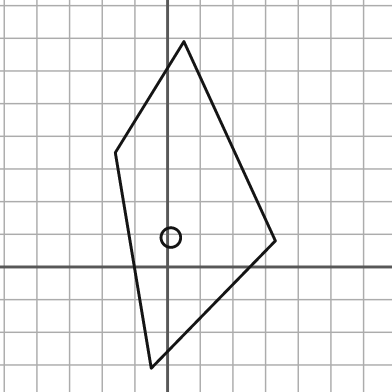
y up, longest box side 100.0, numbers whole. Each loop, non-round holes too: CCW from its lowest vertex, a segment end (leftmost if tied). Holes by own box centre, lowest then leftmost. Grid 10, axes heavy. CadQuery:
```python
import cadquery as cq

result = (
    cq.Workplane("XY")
    .moveTo(-5.0, -31.0)
    .lineTo(33.0, 8.0)
    .lineTo(5.0, 69.0)
    .lineTo(-16.0, 35.0)
    .close()
    .moveTo(1.0, 9.0)
    .circle(3.0)
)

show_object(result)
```